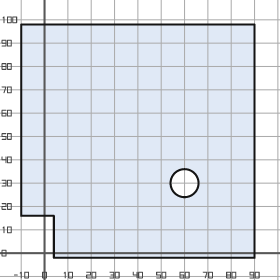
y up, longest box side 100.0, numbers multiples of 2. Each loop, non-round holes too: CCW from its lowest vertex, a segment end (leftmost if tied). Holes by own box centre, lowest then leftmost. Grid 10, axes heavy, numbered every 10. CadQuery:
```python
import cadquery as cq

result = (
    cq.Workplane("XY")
    .moveTo(4.0, -2.0)
    .lineTo(90.0, -2.0)
    .lineTo(90.0, 98.0)
    .lineTo(-10.0, 98.0)
    .lineTo(-10.0, 16.0)
    .lineTo(4.0, 16.0)
    .close()
    .moveTo(60.0, 30.0)
    .circle(6.0)
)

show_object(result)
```